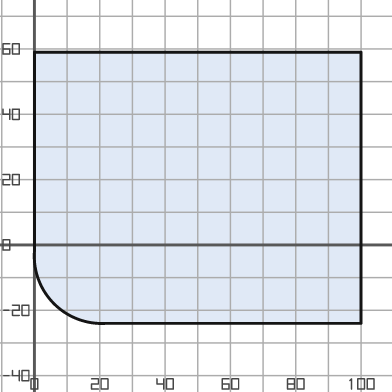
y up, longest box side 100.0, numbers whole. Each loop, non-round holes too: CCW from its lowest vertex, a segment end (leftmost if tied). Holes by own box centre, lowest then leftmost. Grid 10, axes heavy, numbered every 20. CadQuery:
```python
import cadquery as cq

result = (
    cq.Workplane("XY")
    .moveTo(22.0, -24.0)
    .lineTo(100.0, -24.0)
    .lineTo(100.0, 59.0)
    .lineTo(0.0, 59.0)
    .lineTo(0.0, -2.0)
    .threePointArc((6.0, -18.0), (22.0, -24.0))
    .close()
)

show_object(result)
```